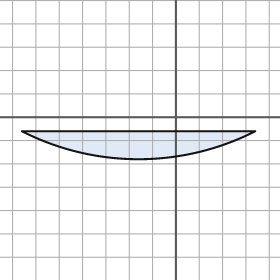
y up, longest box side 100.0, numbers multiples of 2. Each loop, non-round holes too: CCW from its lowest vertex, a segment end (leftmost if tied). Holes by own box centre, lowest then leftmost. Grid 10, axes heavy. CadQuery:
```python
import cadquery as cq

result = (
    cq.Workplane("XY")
    .moveTo(-66.0, -6.0)
    .threePointArc((-16.0, -18.0), (34.0, -6.0))
    .close()
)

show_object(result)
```